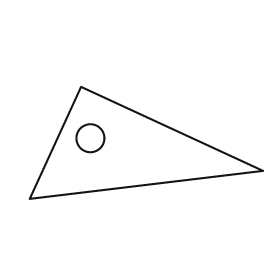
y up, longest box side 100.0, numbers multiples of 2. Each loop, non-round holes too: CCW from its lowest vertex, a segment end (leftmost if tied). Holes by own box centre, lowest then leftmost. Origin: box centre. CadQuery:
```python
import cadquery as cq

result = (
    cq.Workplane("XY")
    .moveTo(-50.0, -24.0)
    .lineTo(50.0, -12.0)
    .lineTo(-28.0, 24.0)
    .close()
    .moveTo(-24.0, 2.0)
    .circle(6.0)
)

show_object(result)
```